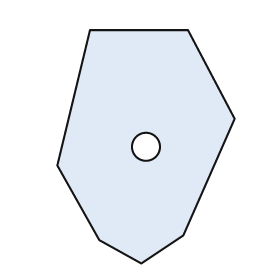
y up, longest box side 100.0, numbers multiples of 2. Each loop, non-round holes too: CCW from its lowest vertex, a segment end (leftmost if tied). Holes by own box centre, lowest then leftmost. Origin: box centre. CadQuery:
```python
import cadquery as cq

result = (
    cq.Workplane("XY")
    .moveTo(-2.0, -50.0)
    .lineTo(16.0, -38.0)
    .lineTo(38.0, 12.0)
    .lineTo(18.0, 50.0)
    .lineTo(-24.0, 50.0)
    .lineTo(-38.0, -8.0)
    .lineTo(-20.0, -40.0)
    .close()
    .moveTo(0.0, 0.0)
    .circle(6.0)
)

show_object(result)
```